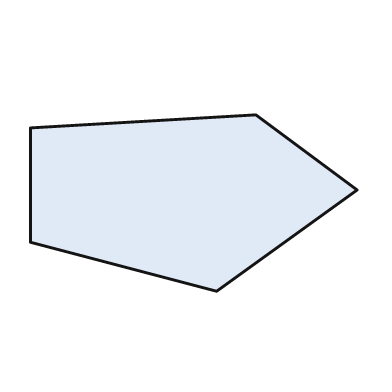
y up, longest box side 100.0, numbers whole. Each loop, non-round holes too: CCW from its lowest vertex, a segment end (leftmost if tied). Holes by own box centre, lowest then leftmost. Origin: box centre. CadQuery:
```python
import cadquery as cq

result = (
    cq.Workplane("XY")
    .moveTo(7.0, -27.0)
    .lineTo(50.0, 4.0)
    .lineTo(19.0, 27.0)
    .lineTo(-50.0, 23.0)
    .lineTo(-50.0, -12.0)
    .close()
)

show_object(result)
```